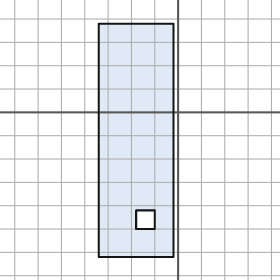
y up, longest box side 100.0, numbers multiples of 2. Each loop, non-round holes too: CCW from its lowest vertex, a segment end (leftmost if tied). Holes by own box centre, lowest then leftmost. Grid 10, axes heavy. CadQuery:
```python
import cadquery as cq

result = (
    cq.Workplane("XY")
    .moveTo(-34.0, -62.0)
    .lineTo(-2.0, -62.0)
    .lineTo(-2.0, 38.0)
    .lineTo(-34.0, 38.0)
    .close()
    .moveTo(-18.0, -50.0)
    .lineTo(-10.0, -50.0)
    .lineTo(-10.0, -42.0)
    .lineTo(-18.0, -42.0)
    .close()
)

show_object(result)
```